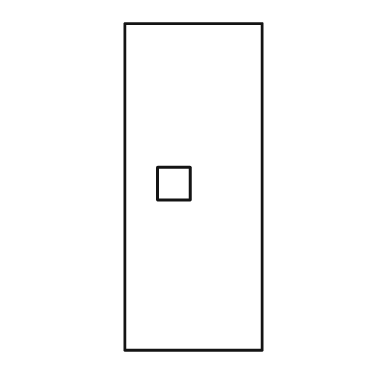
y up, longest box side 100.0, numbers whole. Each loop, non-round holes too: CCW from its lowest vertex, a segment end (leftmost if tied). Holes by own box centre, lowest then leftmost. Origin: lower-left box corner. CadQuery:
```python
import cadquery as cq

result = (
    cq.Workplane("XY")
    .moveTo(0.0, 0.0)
    .lineTo(42.0, 0.0)
    .lineTo(42.0, 100.0)
    .lineTo(0.0, 100.0)
    .close()
    .moveTo(10.0, 46.0)
    .lineTo(20.0, 46.0)
    .lineTo(20.0, 56.0)
    .lineTo(10.0, 56.0)
    .close()
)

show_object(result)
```